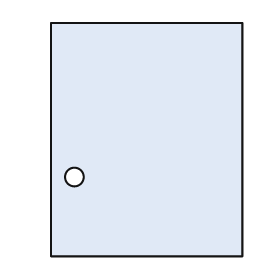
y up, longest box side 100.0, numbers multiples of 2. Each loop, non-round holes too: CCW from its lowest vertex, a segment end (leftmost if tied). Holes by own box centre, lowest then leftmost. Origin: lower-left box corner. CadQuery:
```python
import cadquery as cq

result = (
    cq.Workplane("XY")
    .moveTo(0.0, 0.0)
    .lineTo(82.0, 0.0)
    .lineTo(82.0, 100.0)
    .lineTo(0.0, 100.0)
    .close()
    .moveTo(10.0, 34.0)
    .circle(4.0)
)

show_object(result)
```